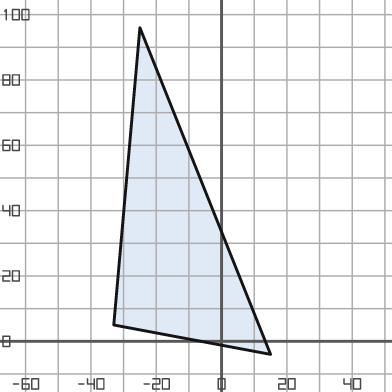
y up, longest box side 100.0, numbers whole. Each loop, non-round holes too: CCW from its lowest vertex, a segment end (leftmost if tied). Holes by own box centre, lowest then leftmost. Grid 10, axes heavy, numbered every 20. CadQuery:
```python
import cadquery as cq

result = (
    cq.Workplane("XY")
    .moveTo(15.0, -4.0)
    .lineTo(-25.0, 96.0)
    .lineTo(-33.0, 5.0)
    .close()
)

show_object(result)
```